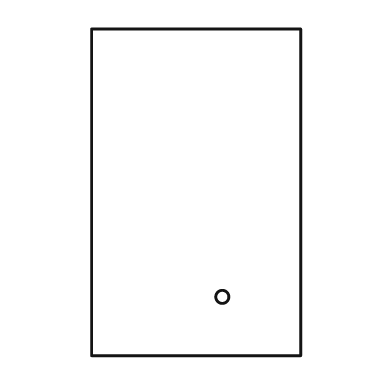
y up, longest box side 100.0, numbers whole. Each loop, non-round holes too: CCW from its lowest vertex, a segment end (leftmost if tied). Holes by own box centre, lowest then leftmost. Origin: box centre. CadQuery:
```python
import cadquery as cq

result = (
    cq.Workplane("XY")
    .moveTo(-32.0, -50.0)
    .lineTo(32.0, -50.0)
    .lineTo(32.0, 50.0)
    .lineTo(-32.0, 50.0)
    .close()
    .moveTo(8.0, -32.0)
    .circle(2.0)
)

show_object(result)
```